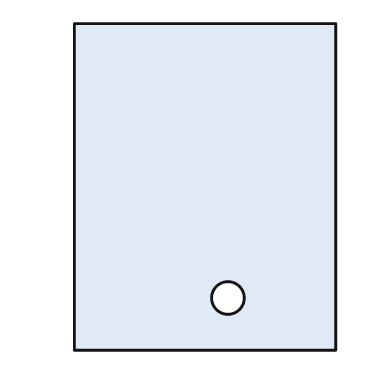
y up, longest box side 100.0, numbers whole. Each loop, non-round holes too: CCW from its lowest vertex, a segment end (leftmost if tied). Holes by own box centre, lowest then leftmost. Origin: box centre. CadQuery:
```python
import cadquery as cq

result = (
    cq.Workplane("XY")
    .moveTo(-40.0, -50.0)
    .lineTo(40.0, -50.0)
    .lineTo(40.0, 50.0)
    .lineTo(-40.0, 50.0)
    .close()
    .moveTo(7.0, -34.0)
    .circle(5.0)
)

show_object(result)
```